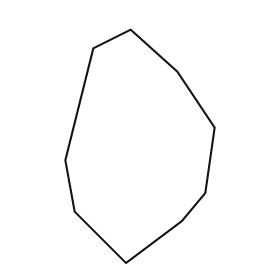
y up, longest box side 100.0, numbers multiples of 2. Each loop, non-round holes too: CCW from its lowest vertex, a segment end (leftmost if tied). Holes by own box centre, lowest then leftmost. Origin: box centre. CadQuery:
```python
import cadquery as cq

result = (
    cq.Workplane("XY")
    .moveTo(-6.0, -50.0)
    .lineTo(18.0, -32.0)
    .lineTo(28.0, -20.0)
    .lineTo(32.0, 8.0)
    .lineTo(16.0, 32.0)
    .lineTo(-4.0, 50.0)
    .lineTo(-20.0, 42.0)
    .lineTo(-32.0, -6.0)
    .lineTo(-28.0, -28.0)
    .close()
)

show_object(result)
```